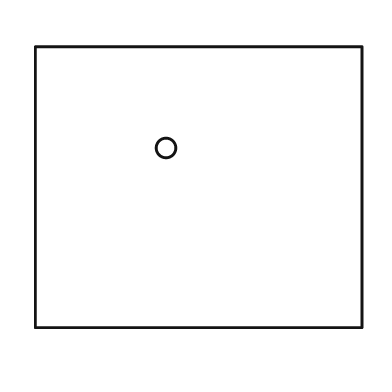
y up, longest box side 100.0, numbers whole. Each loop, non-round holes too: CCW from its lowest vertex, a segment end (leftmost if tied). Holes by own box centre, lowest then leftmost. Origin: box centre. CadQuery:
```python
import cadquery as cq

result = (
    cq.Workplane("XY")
    .moveTo(-50.0, -43.0)
    .lineTo(50.0, -43.0)
    .lineTo(50.0, 43.0)
    .lineTo(-50.0, 43.0)
    .close()
    .moveTo(-10.0, 12.0)
    .circle(3.0)
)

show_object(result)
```